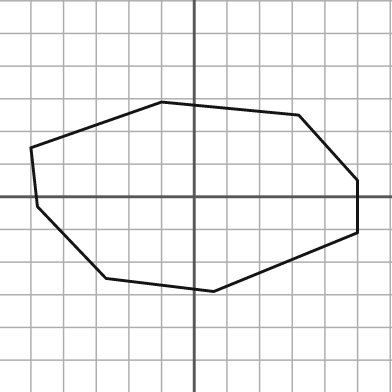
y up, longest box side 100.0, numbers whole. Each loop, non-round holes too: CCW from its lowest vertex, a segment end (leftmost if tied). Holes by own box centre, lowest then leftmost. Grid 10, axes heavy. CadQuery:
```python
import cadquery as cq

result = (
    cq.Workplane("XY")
    .moveTo(6.0, -29.0)
    .lineTo(50.0, -11.0)
    .lineTo(50.0, 5.0)
    .lineTo(32.0, 25.0)
    .lineTo(-10.0, 29.0)
    .lineTo(-50.0, 15.0)
    .lineTo(-48.0, -3.0)
    .lineTo(-27.0, -25.0)
    .close()
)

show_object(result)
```